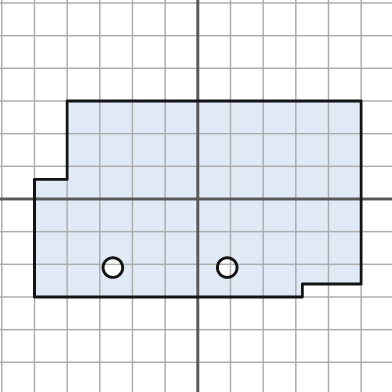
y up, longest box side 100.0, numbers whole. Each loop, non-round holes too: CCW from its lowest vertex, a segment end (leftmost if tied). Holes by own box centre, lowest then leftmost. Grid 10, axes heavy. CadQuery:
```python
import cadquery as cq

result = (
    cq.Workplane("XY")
    .moveTo(-50.0, -30.0)
    .lineTo(32.0, -30.0)
    .lineTo(32.0, -26.0)
    .lineTo(50.0, -26.0)
    .lineTo(50.0, 30.0)
    .lineTo(-40.0, 30.0)
    .lineTo(-40.0, 6.0)
    .lineTo(-50.0, 6.0)
    .close()
    .moveTo(-26.0, -21.0)
    .circle(3.0)
    .moveTo(9.0, -21.0)
    .circle(3.0)
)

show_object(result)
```